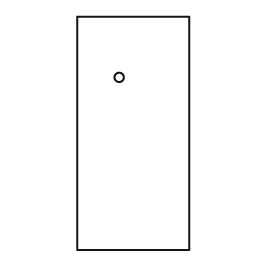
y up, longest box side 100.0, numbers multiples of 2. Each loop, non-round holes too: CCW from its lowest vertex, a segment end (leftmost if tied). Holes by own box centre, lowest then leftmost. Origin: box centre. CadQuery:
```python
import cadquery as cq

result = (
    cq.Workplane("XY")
    .moveTo(-24.0, -50.0)
    .lineTo(24.0, -50.0)
    .lineTo(24.0, 50.0)
    .lineTo(-24.0, 50.0)
    .close()
    .moveTo(-6.0, 24.0)
    .circle(2.0)
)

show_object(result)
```